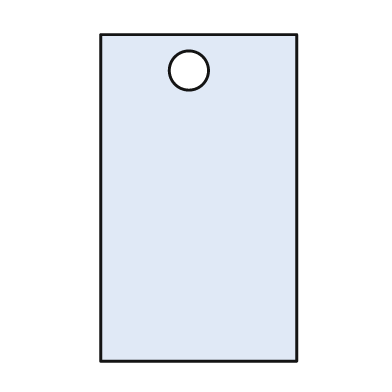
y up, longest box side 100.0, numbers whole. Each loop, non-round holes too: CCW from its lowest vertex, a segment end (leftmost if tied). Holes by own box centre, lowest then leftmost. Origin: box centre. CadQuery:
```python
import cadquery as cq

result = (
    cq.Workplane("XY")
    .moveTo(-30.0, -50.0)
    .lineTo(30.0, -50.0)
    .lineTo(30.0, 50.0)
    .lineTo(-30.0, 50.0)
    .close()
    .moveTo(-3.0, 39.0)
    .circle(6.0)
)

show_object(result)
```